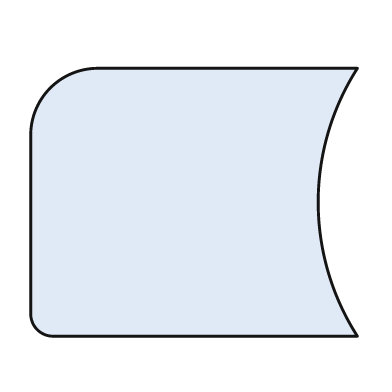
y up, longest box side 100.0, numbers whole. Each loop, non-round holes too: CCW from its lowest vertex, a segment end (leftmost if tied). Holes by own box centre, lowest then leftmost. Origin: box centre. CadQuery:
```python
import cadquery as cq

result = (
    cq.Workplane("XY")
    .moveTo(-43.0, -41.0)
    .lineTo(50.0, -41.0)
    .threePointArc((38.0, 0.0), (50.0, 41.0))
    .lineTo(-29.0, 41.0)
    .threePointArc((-44.0, 35.0), (-50.0, 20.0))
    .lineTo(-50.0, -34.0)
    .threePointArc((-48.0, -39.0), (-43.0, -41.0))
    .close()
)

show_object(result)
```